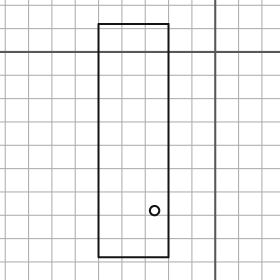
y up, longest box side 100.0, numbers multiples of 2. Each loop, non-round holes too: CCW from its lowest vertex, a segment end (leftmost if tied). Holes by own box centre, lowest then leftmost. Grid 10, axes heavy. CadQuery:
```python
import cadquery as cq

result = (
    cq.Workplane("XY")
    .moveTo(-50.0, -88.0)
    .lineTo(-20.0, -88.0)
    .lineTo(-20.0, 12.0)
    .lineTo(-50.0, 12.0)
    .close()
    .moveTo(-26.0, -68.0)
    .circle(2.0)
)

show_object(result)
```